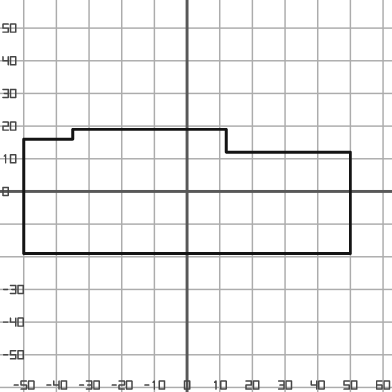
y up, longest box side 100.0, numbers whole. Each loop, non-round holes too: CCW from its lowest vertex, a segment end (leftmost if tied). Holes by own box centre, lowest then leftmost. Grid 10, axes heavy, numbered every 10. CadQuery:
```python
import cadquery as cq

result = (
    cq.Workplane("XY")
    .moveTo(-50.0, -19.0)
    .lineTo(50.0, -19.0)
    .lineTo(50.0, 12.0)
    .lineTo(12.0, 12.0)
    .lineTo(12.0, 19.0)
    .lineTo(-35.0, 19.0)
    .lineTo(-35.0, 16.0)
    .lineTo(-50.0, 16.0)
    .close()
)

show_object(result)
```